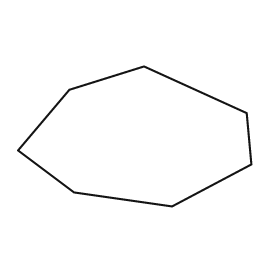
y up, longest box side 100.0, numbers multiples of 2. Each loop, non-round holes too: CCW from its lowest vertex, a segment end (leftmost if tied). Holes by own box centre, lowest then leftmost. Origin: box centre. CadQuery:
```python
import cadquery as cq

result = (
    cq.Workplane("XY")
    .moveTo(16.0, -30.0)
    .lineTo(50.0, -12.0)
    .lineTo(48.0, 10.0)
    .lineTo(4.0, 30.0)
    .lineTo(-28.0, 20.0)
    .lineTo(-50.0, -6.0)
    .lineTo(-26.0, -24.0)
    .close()
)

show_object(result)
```